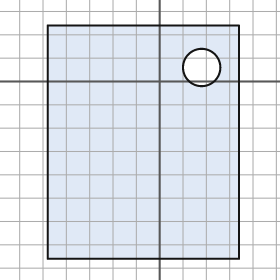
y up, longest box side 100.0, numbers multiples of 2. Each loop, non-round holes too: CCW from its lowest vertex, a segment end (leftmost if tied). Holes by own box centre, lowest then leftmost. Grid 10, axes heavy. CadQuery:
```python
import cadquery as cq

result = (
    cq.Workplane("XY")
    .moveTo(-48.0, -76.0)
    .lineTo(34.0, -76.0)
    .lineTo(34.0, 24.0)
    .lineTo(-48.0, 24.0)
    .close()
    .moveTo(18.0, 6.0)
    .circle(8.0)
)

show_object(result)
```